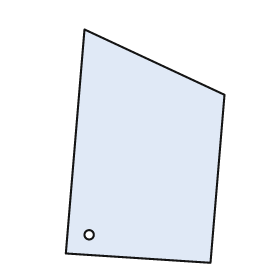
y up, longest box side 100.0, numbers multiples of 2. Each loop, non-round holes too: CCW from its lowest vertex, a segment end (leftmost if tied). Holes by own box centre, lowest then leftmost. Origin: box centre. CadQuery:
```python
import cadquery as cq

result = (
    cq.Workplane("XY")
    .moveTo(28.0, -50.0)
    .lineTo(34.0, 22.0)
    .lineTo(-26.0, 50.0)
    .lineTo(-34.0, -46.0)
    .close()
    .moveTo(-24.0, -38.0)
    .circle(2.0)
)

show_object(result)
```